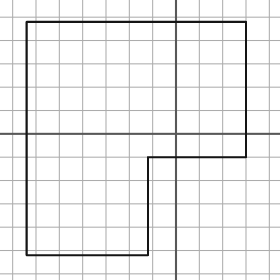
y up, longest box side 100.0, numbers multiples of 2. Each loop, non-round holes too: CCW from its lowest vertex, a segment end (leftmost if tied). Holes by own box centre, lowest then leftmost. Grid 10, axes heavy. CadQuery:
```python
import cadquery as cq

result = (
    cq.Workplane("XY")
    .moveTo(-64.0, -52.0)
    .lineTo(-12.0, -52.0)
    .lineTo(-12.0, -10.0)
    .lineTo(30.0, -10.0)
    .lineTo(30.0, 48.0)
    .lineTo(-64.0, 48.0)
    .close()
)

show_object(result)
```